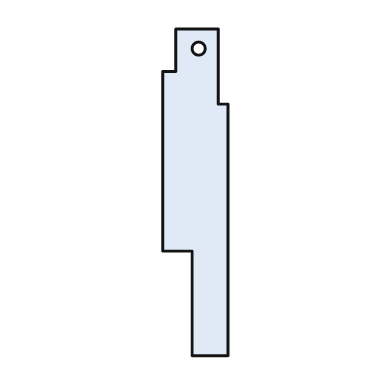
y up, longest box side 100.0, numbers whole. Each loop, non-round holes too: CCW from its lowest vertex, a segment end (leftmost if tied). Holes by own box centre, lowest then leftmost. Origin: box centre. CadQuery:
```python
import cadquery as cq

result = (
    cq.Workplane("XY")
    .moveTo(-1.0, -50.0)
    .lineTo(10.0, -50.0)
    .lineTo(10.0, 27.0)
    .lineTo(7.0, 27.0)
    .lineTo(7.0, 50.0)
    .lineTo(-6.0, 50.0)
    .lineTo(-6.0, 37.0)
    .lineTo(-10.0, 37.0)
    .lineTo(-10.0, -18.0)
    .lineTo(-1.0, -18.0)
    .close()
    .moveTo(1.0, 44.0)
    .circle(2.0)
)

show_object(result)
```